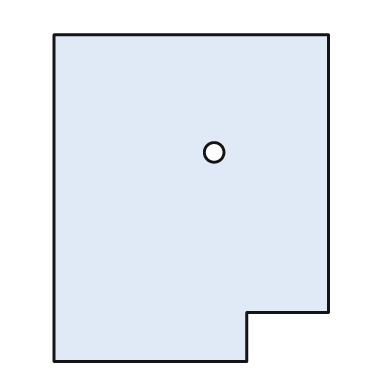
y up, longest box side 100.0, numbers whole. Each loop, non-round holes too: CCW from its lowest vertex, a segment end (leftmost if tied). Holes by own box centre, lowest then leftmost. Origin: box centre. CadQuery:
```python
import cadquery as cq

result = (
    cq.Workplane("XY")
    .moveTo(-42.0, -50.0)
    .lineTo(17.0, -50.0)
    .lineTo(17.0, -35.0)
    .lineTo(42.0, -35.0)
    .lineTo(42.0, 50.0)
    .lineTo(-42.0, 50.0)
    .close()
    .moveTo(7.0, 14.0)
    .circle(3.0)
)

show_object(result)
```